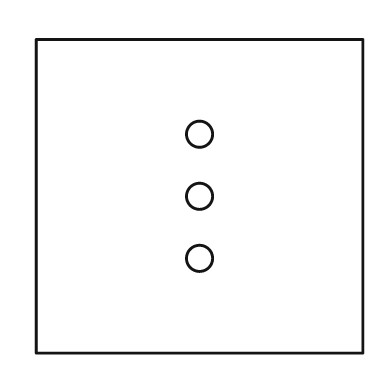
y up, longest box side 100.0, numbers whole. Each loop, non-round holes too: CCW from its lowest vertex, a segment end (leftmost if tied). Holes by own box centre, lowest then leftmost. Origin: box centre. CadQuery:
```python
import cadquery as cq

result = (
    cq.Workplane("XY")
    .moveTo(-50.0, -48.0)
    .lineTo(50.0, -48.0)
    .lineTo(50.0, 48.0)
    .lineTo(-50.0, 48.0)
    .close()
    .moveTo(0.0, -19.0)
    .circle(4.0)
    .moveTo(0.0, 0.0)
    .circle(4.0)
    .moveTo(0.0, 19.0)
    .circle(4.0)
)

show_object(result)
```